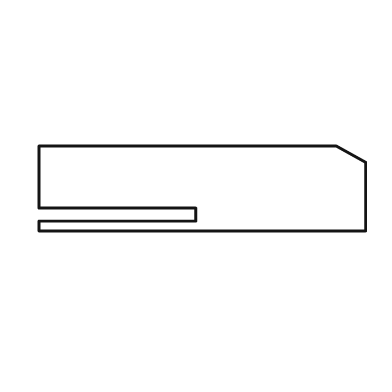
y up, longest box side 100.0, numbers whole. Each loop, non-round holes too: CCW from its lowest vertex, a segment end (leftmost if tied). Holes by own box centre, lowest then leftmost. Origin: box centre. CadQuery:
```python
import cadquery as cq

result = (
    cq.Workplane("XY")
    .moveTo(-50.0, -13.0)
    .lineTo(50.0, -13.0)
    .lineTo(50.0, 8.0)
    .lineTo(41.0, 13.0)
    .lineTo(-50.0, 13.0)
    .lineTo(-50.0, -6.0)
    .lineTo(-2.0, -6.0)
    .lineTo(-2.0, -10.0)
    .lineTo(-50.0, -10.0)
    .close()
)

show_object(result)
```